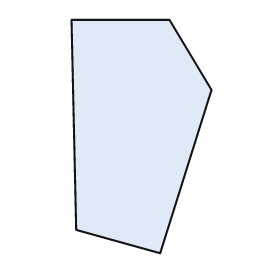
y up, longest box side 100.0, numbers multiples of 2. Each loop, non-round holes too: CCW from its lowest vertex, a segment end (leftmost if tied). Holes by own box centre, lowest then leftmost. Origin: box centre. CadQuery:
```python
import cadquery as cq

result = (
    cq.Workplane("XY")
    .moveTo(8.0, -50.0)
    .lineTo(30.0, 20.0)
    .lineTo(12.0, 50.0)
    .lineTo(-30.0, 50.0)
    .lineTo(-28.0, -40.0)
    .close()
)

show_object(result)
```